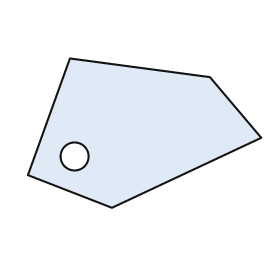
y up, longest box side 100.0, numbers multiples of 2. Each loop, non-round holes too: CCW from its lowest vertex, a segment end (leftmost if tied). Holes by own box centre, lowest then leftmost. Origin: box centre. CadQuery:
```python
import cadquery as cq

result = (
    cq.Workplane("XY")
    .moveTo(-14.0, -32.0)
    .lineTo(50.0, -2.0)
    .lineTo(28.0, 24.0)
    .lineTo(-32.0, 32.0)
    .lineTo(-50.0, -18.0)
    .close()
    .moveTo(-30.0, -10.0)
    .circle(6.0)
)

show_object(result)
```